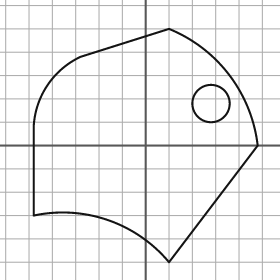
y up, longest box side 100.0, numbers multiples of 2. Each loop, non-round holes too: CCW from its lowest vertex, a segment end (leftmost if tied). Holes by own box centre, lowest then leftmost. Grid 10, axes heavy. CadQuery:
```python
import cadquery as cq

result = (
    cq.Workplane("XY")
    .moveTo(10.0, -50.0)
    .lineTo(48.0, 0.0)
    .threePointArc((36.0, 30.0), (10.0, 50.0))
    .lineTo(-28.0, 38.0)
    .threePointArc((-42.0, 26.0), (-48.0, 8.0))
    .lineTo(-48.0, -30.0)
    .threePointArc((-16.0, -32.0), (10.0, -50.0))
    .close()
    .moveTo(28.0, 18.0)
    .circle(8.0)
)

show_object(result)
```